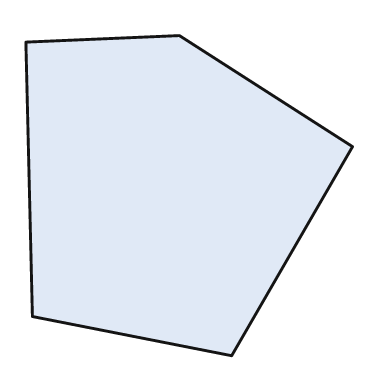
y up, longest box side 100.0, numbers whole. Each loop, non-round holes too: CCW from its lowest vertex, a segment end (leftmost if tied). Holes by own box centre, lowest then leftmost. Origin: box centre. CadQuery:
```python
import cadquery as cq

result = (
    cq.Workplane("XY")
    .moveTo(13.0, -49.0)
    .lineTo(50.0, 15.0)
    .lineTo(-3.0, 49.0)
    .lineTo(-50.0, 47.0)
    .lineTo(-48.0, -37.0)
    .close()
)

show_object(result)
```